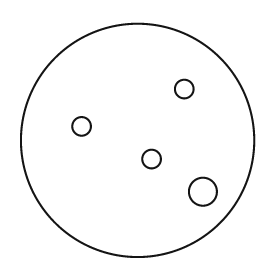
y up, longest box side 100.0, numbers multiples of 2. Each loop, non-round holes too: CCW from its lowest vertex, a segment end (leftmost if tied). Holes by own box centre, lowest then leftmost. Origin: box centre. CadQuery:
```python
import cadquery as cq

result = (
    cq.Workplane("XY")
    .moveTo(0.0, 0.0)
    .circle(50.0)
    .moveTo(28.0, -22.0)
    .circle(6.0)
    .moveTo(6.0, -8.0)
    .circle(4.0)
    .moveTo(-24.0, 6.0)
    .circle(4.0)
    .moveTo(20.0, 22.0)
    .circle(4.0)
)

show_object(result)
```